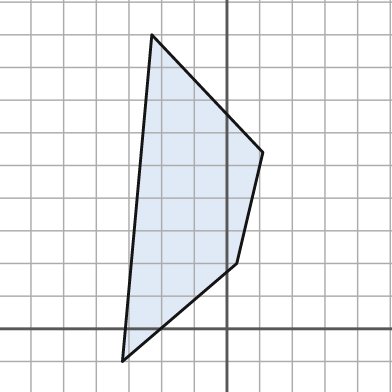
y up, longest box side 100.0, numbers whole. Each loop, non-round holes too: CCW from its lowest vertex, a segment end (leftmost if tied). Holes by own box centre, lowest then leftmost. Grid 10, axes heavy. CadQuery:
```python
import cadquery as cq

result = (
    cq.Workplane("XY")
    .moveTo(-32.0, -10.0)
    .lineTo(3.0, 20.0)
    .lineTo(11.0, 54.0)
    .lineTo(-23.0, 90.0)
    .close()
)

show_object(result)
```